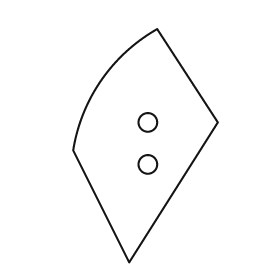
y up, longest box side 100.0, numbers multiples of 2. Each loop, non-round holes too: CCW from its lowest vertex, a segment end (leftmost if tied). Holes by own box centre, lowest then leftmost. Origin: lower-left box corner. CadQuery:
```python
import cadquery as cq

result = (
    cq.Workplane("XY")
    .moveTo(24.0, 0.0)
    .lineTo(62.0, 60.0)
    .lineTo(36.0, 100.0)
    .threePointArc((12.0, 78.0), (0.0, 48.0))
    .close()
    .moveTo(32.0, 42.0)
    .circle(4.0)
    .moveTo(32.0, 60.0)
    .circle(4.0)
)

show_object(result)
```